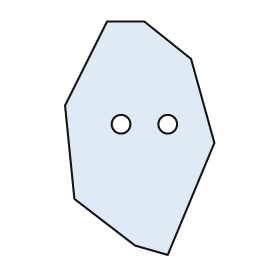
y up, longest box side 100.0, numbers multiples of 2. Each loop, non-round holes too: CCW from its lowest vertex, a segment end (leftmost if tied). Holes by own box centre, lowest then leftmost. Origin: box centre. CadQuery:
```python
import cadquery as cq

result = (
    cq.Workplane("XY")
    .moveTo(12.0, -50.0)
    .lineTo(32.0, -2.0)
    .lineTo(22.0, 34.0)
    .lineTo(2.0, 50.0)
    .lineTo(-14.0, 50.0)
    .lineTo(-32.0, 14.0)
    .lineTo(-28.0, -26.0)
    .lineTo(-2.0, -46.0)
    .close()
    .moveTo(-8.0, 6.0)
    .circle(4.0)
    .moveTo(12.0, 6.0)
    .circle(4.0)
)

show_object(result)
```